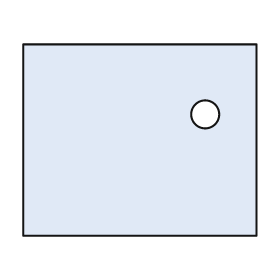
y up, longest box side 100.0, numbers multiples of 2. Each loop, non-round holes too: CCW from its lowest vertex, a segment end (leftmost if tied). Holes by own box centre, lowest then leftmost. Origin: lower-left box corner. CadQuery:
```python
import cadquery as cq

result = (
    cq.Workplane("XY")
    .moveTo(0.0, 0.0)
    .lineTo(100.0, 0.0)
    .lineTo(100.0, 82.0)
    .lineTo(0.0, 82.0)
    .close()
    .moveTo(78.0, 52.0)
    .circle(6.0)
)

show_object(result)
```